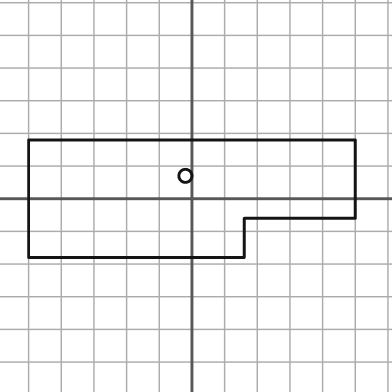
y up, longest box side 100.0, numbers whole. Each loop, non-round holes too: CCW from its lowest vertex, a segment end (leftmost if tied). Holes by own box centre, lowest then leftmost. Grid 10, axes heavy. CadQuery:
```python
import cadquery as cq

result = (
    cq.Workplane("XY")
    .moveTo(-50.0, -18.0)
    .lineTo(16.0, -18.0)
    .lineTo(16.0, -6.0)
    .lineTo(50.0, -6.0)
    .lineTo(50.0, 18.0)
    .lineTo(-50.0, 18.0)
    .close()
    .moveTo(-2.0, 7.0)
    .circle(2.0)
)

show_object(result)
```